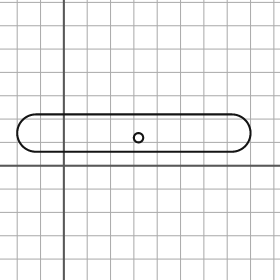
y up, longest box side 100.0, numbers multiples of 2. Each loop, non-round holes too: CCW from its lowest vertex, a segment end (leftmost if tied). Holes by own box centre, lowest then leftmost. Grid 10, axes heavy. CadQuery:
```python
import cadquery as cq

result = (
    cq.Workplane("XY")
    .moveTo(-12.0, 6.0)
    .lineTo(72.0, 6.0)
    .threePointArc((80.0, 14.0), (72.0, 22.0))
    .lineTo(-12.0, 22.0)
    .threePointArc((-20.0, 14.0), (-12.0, 6.0))
    .close()
    .moveTo(32.0, 12.0)
    .circle(2.0)
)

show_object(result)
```